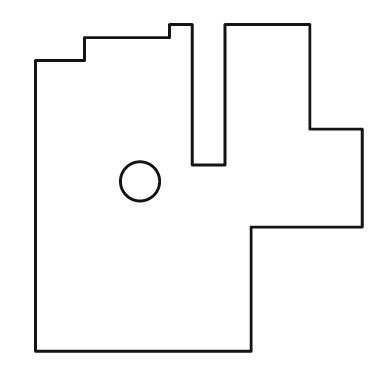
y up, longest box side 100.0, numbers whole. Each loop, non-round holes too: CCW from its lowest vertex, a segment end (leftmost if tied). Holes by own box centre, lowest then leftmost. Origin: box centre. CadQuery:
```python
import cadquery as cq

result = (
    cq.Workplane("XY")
    .moveTo(-50.0, -50.0)
    .lineTo(16.0, -50.0)
    .lineTo(16.0, -12.0)
    .lineTo(50.0, -12.0)
    .lineTo(50.0, 18.0)
    .lineTo(34.0, 18.0)
    .lineTo(34.0, 50.0)
    .lineTo(8.0, 50.0)
    .lineTo(8.0, 7.0)
    .lineTo(-2.0, 7.0)
    .lineTo(-2.0, 50.0)
    .lineTo(-9.0, 50.0)
    .lineTo(-9.0, 46.0)
    .lineTo(-35.0, 46.0)
    .lineTo(-35.0, 39.0)
    .lineTo(-50.0, 39.0)
    .close()
    .moveTo(-18.0, 2.0)
    .circle(6.0)
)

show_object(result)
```